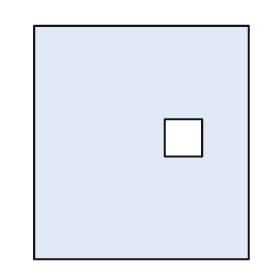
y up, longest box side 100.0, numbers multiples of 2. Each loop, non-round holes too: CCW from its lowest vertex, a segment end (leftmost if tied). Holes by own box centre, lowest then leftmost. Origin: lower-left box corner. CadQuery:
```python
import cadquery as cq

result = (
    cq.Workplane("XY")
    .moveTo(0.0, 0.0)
    .lineTo(92.0, 0.0)
    .lineTo(92.0, 100.0)
    .lineTo(0.0, 100.0)
    .close()
    .moveTo(56.0, 44.0)
    .lineTo(72.0, 44.0)
    .lineTo(72.0, 60.0)
    .lineTo(56.0, 60.0)
    .close()
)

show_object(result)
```